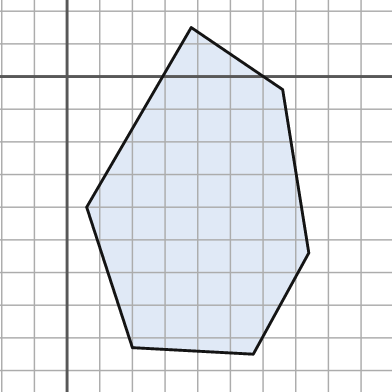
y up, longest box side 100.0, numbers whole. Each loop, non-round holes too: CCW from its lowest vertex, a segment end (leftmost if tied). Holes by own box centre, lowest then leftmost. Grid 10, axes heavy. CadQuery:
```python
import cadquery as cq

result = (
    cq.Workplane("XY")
    .moveTo(57.0, -85.0)
    .lineTo(74.0, -54.0)
    .lineTo(66.0, -4.0)
    .lineTo(38.0, 15.0)
    .lineTo(6.0, -40.0)
    .lineTo(20.0, -83.0)
    .close()
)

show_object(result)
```